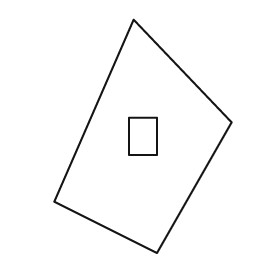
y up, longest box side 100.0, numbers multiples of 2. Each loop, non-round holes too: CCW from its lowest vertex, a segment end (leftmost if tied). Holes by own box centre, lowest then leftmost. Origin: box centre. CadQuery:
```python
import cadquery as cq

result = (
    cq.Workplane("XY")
    .moveTo(6.0, -50.0)
    .lineTo(38.0, 6.0)
    .lineTo(-4.0, 50.0)
    .lineTo(-38.0, -28.0)
    .close()
    .moveTo(-6.0, -8.0)
    .lineTo(6.0, -8.0)
    .lineTo(6.0, 8.0)
    .lineTo(-6.0, 8.0)
    .close()
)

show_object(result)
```